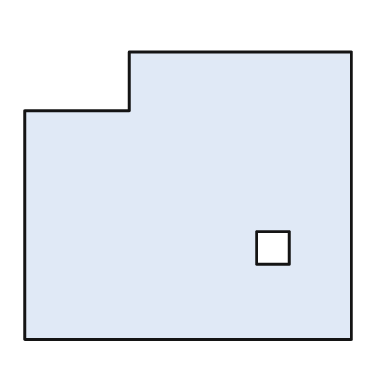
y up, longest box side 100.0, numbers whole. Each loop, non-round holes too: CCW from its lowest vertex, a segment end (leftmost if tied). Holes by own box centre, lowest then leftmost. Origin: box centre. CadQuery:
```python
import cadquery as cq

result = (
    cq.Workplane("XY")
    .moveTo(-50.0, -44.0)
    .lineTo(50.0, -44.0)
    .lineTo(50.0, 44.0)
    .lineTo(-18.0, 44.0)
    .lineTo(-18.0, 26.0)
    .lineTo(-50.0, 26.0)
    .close()
    .moveTo(21.0, -21.0)
    .lineTo(31.0, -21.0)
    .lineTo(31.0, -11.0)
    .lineTo(21.0, -11.0)
    .close()
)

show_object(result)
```